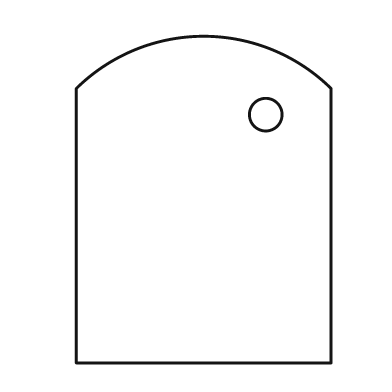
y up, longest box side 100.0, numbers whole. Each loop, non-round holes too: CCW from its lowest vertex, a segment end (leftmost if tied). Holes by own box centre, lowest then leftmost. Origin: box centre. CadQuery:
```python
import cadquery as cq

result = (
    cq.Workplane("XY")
    .moveTo(-39.0, -50.0)
    .lineTo(39.0, -50.0)
    .lineTo(39.0, 34.0)
    .threePointArc((0.0, 50.0), (-39.0, 34.0))
    .close()
    .moveTo(19.0, 26.0)
    .circle(5.0)
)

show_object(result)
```